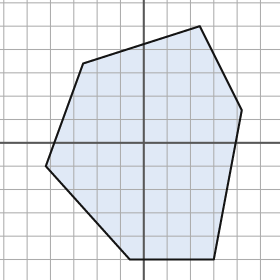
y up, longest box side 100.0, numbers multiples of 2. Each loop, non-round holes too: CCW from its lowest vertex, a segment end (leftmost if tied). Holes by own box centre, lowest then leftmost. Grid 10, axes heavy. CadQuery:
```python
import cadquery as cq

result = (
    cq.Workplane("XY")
    .moveTo(-6.0, -50.0)
    .lineTo(30.0, -50.0)
    .lineTo(42.0, 14.0)
    .lineTo(24.0, 50.0)
    .lineTo(-26.0, 34.0)
    .lineTo(-42.0, -10.0)
    .close()
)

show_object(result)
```